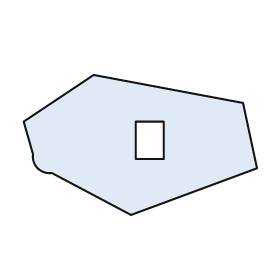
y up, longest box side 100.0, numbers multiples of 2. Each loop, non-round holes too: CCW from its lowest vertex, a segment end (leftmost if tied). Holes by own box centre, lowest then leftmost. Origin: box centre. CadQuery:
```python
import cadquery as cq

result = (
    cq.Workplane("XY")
    .moveTo(-4.0, -30.0)
    .lineTo(50.0, -10.0)
    .lineTo(44.0, 18.0)
    .lineTo(-20.0, 30.0)
    .lineTo(-50.0, 10.0)
    .lineTo(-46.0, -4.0)
    .threePointArc((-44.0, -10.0), (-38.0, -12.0))
    .close()
    .moveTo(-2.0, -6.0)
    .lineTo(10.0, -6.0)
    .lineTo(10.0, 10.0)
    .lineTo(-2.0, 10.0)
    .close()
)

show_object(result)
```